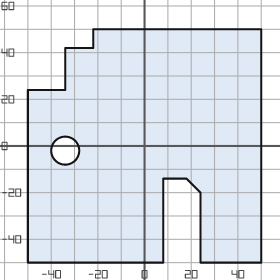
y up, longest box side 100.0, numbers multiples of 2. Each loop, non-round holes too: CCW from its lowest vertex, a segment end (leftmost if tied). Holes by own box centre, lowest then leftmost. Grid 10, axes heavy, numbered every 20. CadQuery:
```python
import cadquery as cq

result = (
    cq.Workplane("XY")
    .moveTo(-50.0, -50.0)
    .lineTo(8.0, -50.0)
    .lineTo(8.0, -14.0)
    .lineTo(18.0, -14.0)
    .lineTo(24.0, -20.0)
    .lineTo(24.0, -50.0)
    .lineTo(50.0, -50.0)
    .lineTo(50.0, 50.0)
    .lineTo(-22.0, 50.0)
    .lineTo(-22.0, 42.0)
    .lineTo(-34.0, 42.0)
    .lineTo(-34.0, 24.0)
    .lineTo(-50.0, 24.0)
    .close()
    .moveTo(-34.0, -2.0)
    .circle(6.0)
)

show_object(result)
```